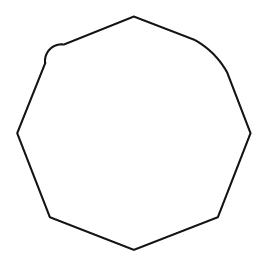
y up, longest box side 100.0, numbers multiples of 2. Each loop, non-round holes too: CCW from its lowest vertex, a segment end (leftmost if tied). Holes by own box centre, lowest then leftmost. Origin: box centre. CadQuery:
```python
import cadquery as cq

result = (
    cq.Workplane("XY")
    .moveTo(0.0, -50.0)
    .lineTo(36.0, -36.0)
    .lineTo(50.0, 0.0)
    .lineTo(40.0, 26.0)
    .threePointArc((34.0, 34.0), (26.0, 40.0))
    .lineTo(0.0, 50.0)
    .lineTo(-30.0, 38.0)
    .threePointArc((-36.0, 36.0), (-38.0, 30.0))
    .lineTo(-50.0, 0.0)
    .lineTo(-36.0, -36.0)
    .close()
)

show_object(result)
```